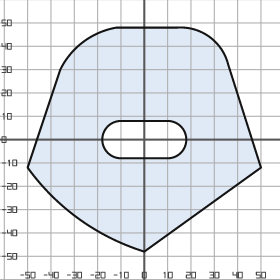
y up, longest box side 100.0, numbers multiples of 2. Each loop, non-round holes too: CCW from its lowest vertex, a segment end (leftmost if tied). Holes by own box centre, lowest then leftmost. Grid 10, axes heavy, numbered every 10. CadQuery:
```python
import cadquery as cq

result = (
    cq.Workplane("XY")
    .moveTo(0.0, -48.0)
    .lineTo(50.0, -12.0)
    .lineTo(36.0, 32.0)
    .threePointArc((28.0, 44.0), (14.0, 48.0))
    .lineTo(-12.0, 48.0)
    .threePointArc((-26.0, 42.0), (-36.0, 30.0))
    .lineTo(-50.0, -12.0)
    .threePointArc((-28.0, -34.0), (0.0, -48.0))
    .close()
    .moveTo(-10.0, -8.0)
    .lineTo(10.0, -8.0)
    .threePointArc((18.0, 0.0), (10.0, 8.0))
    .lineTo(-10.0, 8.0)
    .threePointArc((-18.0, 0.0), (-10.0, -8.0))
    .close()
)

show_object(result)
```